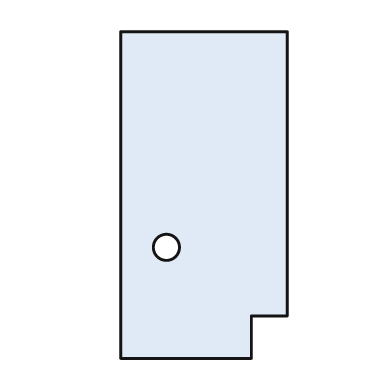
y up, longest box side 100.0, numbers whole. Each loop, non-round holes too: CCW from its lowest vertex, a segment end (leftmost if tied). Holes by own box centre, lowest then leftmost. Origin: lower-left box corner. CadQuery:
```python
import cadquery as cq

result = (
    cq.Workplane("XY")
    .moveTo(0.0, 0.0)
    .lineTo(40.0, 0.0)
    .lineTo(40.0, 13.0)
    .lineTo(51.0, 13.0)
    .lineTo(51.0, 100.0)
    .lineTo(0.0, 100.0)
    .close()
    .moveTo(14.0, 34.0)
    .circle(4.0)
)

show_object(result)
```